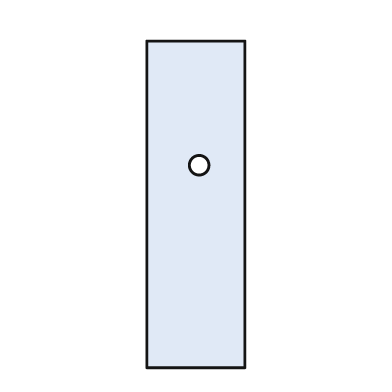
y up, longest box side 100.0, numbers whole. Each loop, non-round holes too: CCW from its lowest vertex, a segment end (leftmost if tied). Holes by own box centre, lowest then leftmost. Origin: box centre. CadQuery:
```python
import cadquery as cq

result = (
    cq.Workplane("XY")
    .moveTo(-15.0, -50.0)
    .lineTo(15.0, -50.0)
    .lineTo(15.0, 50.0)
    .lineTo(-15.0, 50.0)
    .close()
    .moveTo(1.0, 12.0)
    .circle(3.0)
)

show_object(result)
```